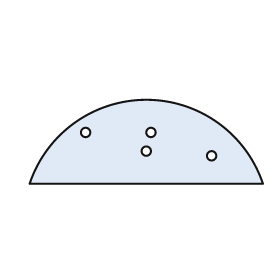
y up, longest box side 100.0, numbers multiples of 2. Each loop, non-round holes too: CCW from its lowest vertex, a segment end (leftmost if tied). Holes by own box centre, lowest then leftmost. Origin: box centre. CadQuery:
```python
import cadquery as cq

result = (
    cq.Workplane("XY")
    .moveTo(-50.0, -18.0)
    .lineTo(50.0, -18.0)
    .threePointArc((0.0, 18.0), (-50.0, -18.0))
    .close()
    .moveTo(28.0, -6.0)
    .circle(2.0)
    .moveTo(0.0, -4.0)
    .circle(2.0)
    .moveTo(-26.0, 4.0)
    .circle(2.0)
    .moveTo(2.0, 4.0)
    .circle(2.0)
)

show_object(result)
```